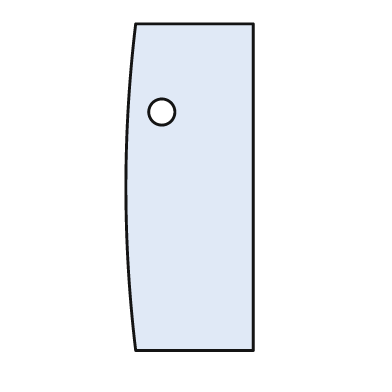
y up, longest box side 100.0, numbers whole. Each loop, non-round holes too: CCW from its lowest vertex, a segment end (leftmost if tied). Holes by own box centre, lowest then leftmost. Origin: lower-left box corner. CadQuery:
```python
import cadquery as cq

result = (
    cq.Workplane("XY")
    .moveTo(3.0, 0.0)
    .lineTo(39.0, 0.0)
    .lineTo(39.0, 100.0)
    .lineTo(3.0, 100.0)
    .threePointArc((0.0, 50.0), (3.0, 0.0))
    .close()
    .moveTo(11.0, 73.0)
    .circle(4.0)
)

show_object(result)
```